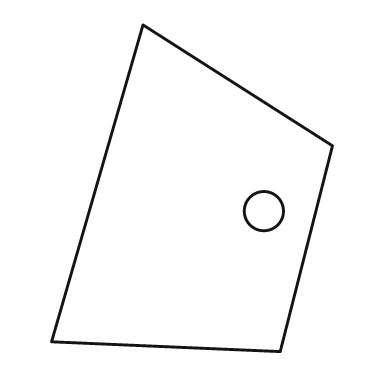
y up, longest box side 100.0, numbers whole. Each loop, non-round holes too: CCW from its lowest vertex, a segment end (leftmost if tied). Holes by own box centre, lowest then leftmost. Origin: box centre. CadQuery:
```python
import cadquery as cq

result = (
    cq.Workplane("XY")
    .moveTo(27.0, -50.0)
    .lineTo(43.0, 13.0)
    .lineTo(-15.0, 50.0)
    .lineTo(-43.0, -47.0)
    .close()
    .moveTo(22.0, -7.0)
    .circle(6.0)
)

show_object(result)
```